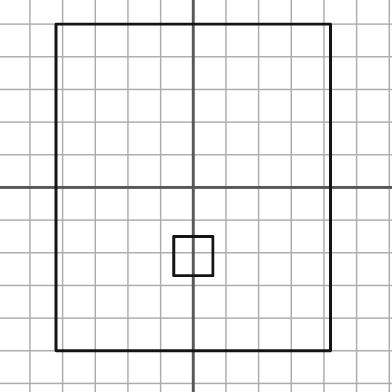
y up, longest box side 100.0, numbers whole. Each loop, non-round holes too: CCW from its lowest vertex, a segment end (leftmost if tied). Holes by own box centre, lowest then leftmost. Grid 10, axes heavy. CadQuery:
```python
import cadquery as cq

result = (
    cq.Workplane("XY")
    .moveTo(-42.0, -50.0)
    .lineTo(42.0, -50.0)
    .lineTo(42.0, 50.0)
    .lineTo(-42.0, 50.0)
    .close()
    .moveTo(-6.0, -27.0)
    .lineTo(6.0, -27.0)
    .lineTo(6.0, -15.0)
    .lineTo(-6.0, -15.0)
    .close()
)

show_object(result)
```